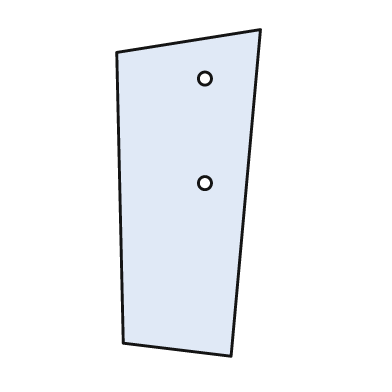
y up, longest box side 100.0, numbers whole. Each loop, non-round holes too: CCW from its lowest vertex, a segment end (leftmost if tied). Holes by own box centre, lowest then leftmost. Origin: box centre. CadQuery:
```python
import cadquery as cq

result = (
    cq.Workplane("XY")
    .moveTo(13.0, -50.0)
    .lineTo(22.0, 50.0)
    .lineTo(-22.0, 43.0)
    .lineTo(-20.0, -46.0)
    .close()
    .moveTo(5.0, 3.0)
    .circle(2.0)
    .moveTo(5.0, 35.0)
    .circle(2.0)
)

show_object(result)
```